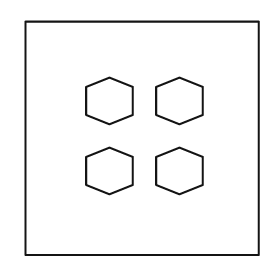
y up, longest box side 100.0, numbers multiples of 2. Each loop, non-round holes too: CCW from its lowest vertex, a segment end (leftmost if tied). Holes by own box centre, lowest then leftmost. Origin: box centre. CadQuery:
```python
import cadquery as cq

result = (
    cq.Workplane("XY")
    .moveTo(-50.0, -50.0)
    .lineTo(50.0, -50.0)
    .lineTo(50.0, 50.0)
    .lineTo(-50.0, 50.0)
    .close()
    .moveTo(-14.0, -24.0)
    .lineTo(-4.0, -20.0)
    .lineTo(-4.0, -8.0)
    .lineTo(-14.0, -4.0)
    .lineTo(-24.0, -8.0)
    .lineTo(-24.0, -20.0)
    .close()
    .moveTo(16.0, -24.0)
    .lineTo(26.0, -20.0)
    .lineTo(26.0, -8.0)
    .lineTo(16.0, -4.0)
    .lineTo(6.0, -8.0)
    .lineTo(6.0, -20.0)
    .close()
    .moveTo(-14.0, 6.0)
    .lineTo(-4.0, 10.0)
    .lineTo(-4.0, 22.0)
    .lineTo(-14.0, 26.0)
    .lineTo(-24.0, 22.0)
    .lineTo(-24.0, 10.0)
    .close()
    .moveTo(16.0, 6.0)
    .lineTo(26.0, 10.0)
    .lineTo(26.0, 22.0)
    .lineTo(16.0, 26.0)
    .lineTo(6.0, 22.0)
    .lineTo(6.0, 10.0)
    .close()
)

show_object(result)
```